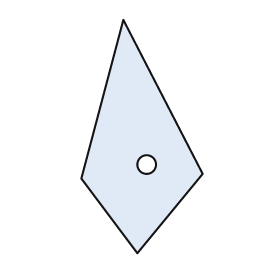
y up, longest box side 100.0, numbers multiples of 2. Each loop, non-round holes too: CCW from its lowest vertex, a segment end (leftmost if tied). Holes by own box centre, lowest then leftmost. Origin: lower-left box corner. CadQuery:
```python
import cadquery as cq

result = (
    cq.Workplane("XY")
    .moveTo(24.0, 0.0)
    .lineTo(52.0, 34.0)
    .lineTo(18.0, 100.0)
    .lineTo(0.0, 32.0)
    .close()
    .moveTo(28.0, 38.0)
    .circle(4.0)
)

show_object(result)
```